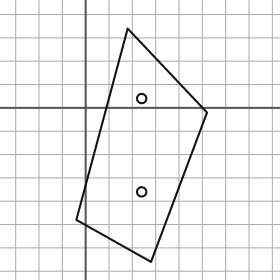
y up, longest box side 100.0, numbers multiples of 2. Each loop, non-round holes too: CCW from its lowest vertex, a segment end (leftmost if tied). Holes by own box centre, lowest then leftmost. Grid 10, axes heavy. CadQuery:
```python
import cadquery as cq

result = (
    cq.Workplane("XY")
    .moveTo(28.0, -66.0)
    .lineTo(52.0, -2.0)
    .lineTo(18.0, 34.0)
    .lineTo(-4.0, -48.0)
    .close()
    .moveTo(24.0, -36.0)
    .circle(2.0)
    .moveTo(24.0, 4.0)
    .circle(2.0)
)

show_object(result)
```